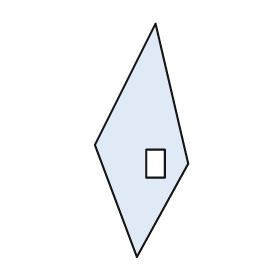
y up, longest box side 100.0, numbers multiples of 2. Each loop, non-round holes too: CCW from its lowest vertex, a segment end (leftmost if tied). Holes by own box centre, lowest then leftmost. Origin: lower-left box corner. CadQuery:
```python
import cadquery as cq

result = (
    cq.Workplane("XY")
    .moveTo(18.0, 0.0)
    .lineTo(40.0, 40.0)
    .lineTo(26.0, 100.0)
    .lineTo(0.0, 48.0)
    .close()
    .moveTo(22.0, 34.0)
    .lineTo(30.0, 34.0)
    .lineTo(30.0, 46.0)
    .lineTo(22.0, 46.0)
    .close()
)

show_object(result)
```